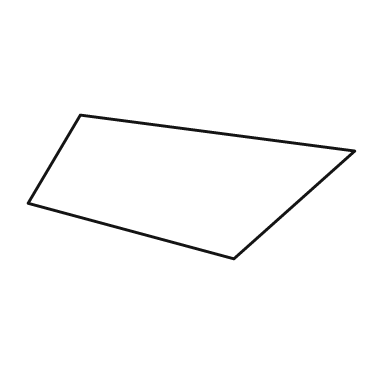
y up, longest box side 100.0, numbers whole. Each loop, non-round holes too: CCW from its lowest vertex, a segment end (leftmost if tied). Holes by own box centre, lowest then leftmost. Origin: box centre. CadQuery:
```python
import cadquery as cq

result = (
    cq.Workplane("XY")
    .moveTo(13.0, -22.0)
    .lineTo(50.0, 11.0)
    .lineTo(-34.0, 22.0)
    .lineTo(-50.0, -5.0)
    .close()
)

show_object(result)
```